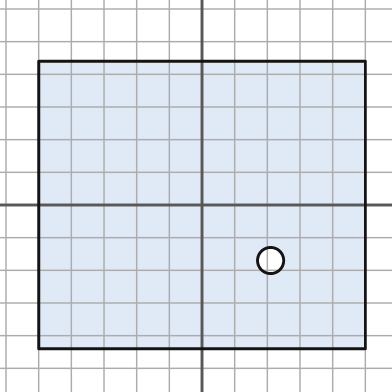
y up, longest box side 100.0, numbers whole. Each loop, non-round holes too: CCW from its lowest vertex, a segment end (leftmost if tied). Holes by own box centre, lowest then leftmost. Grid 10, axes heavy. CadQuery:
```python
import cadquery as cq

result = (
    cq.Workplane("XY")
    .moveTo(-50.0, -44.0)
    .lineTo(50.0, -44.0)
    .lineTo(50.0, 44.0)
    .lineTo(-50.0, 44.0)
    .close()
    .moveTo(21.0, -17.0)
    .circle(4.0)
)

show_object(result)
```